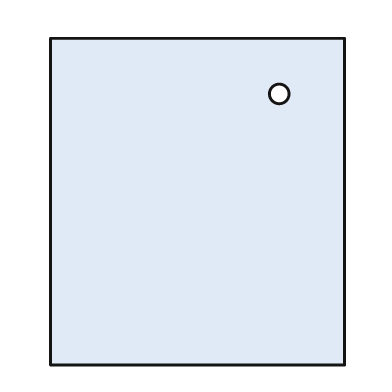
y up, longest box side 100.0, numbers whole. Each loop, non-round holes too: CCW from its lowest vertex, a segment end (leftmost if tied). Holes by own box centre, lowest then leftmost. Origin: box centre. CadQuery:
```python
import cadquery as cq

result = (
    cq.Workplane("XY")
    .moveTo(-45.0, -50.0)
    .lineTo(45.0, -50.0)
    .lineTo(45.0, 50.0)
    .lineTo(-45.0, 50.0)
    .close()
    .moveTo(25.0, 33.0)
    .circle(3.0)
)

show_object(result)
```